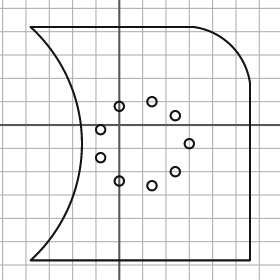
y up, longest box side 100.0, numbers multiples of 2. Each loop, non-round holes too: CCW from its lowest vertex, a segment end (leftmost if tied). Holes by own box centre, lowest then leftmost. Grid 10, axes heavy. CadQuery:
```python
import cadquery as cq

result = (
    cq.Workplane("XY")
    .moveTo(-38.0, -58.0)
    .lineTo(56.0, -58.0)
    .lineTo(56.0, 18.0)
    .threePointArc((48.0, 34.0), (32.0, 42.0))
    .lineTo(-38.0, 42.0)
    .threePointArc((-16.0, -8.0), (-38.0, -58.0))
    .close()
    .moveTo(14.0, -26.0)
    .circle(2.0)
    .moveTo(0.0, -24.0)
    .circle(2.0)
    .moveTo(24.0, -20.0)
    .circle(2.0)
    .moveTo(-8.0, -14.0)
    .circle(2.0)
    .moveTo(30.0, -8.0)
    .circle(2.0)
    .moveTo(-8.0, -2.0)
    .circle(2.0)
    .moveTo(24.0, 4.0)
    .circle(2.0)
    .moveTo(0.0, 8.0)
    .circle(2.0)
    .moveTo(14.0, 10.0)
    .circle(2.0)
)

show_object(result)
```